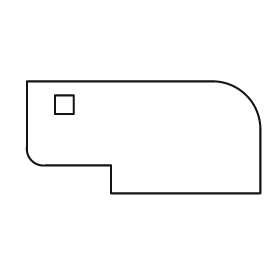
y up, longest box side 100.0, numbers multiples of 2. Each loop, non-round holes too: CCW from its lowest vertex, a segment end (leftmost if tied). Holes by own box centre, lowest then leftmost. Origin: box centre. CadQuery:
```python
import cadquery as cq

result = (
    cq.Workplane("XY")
    .moveTo(-14.0, -24.0)
    .lineTo(50.0, -24.0)
    .lineTo(50.0, 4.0)
    .threePointArc((44.0, 18.0), (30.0, 24.0))
    .lineTo(-50.0, 24.0)
    .lineTo(-50.0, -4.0)
    .threePointArc((-48.0, -10.0), (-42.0, -12.0))
    .lineTo(-14.0, -12.0)
    .close()
    .moveTo(-38.0, 10.0)
    .lineTo(-30.0, 10.0)
    .lineTo(-30.0, 18.0)
    .lineTo(-38.0, 18.0)
    .close()
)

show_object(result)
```